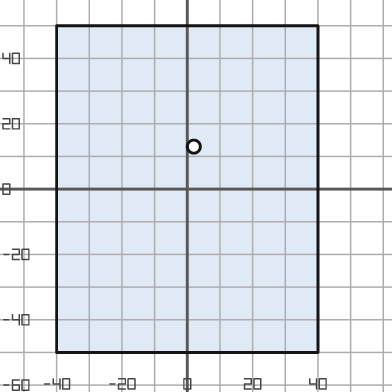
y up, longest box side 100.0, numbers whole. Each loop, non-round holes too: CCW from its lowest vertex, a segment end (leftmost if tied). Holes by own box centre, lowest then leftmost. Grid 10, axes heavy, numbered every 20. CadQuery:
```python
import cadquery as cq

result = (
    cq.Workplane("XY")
    .moveTo(-40.0, -50.0)
    .lineTo(40.0, -50.0)
    .lineTo(40.0, 50.0)
    .lineTo(-40.0, 50.0)
    .close()
    .moveTo(2.0, 13.0)
    .circle(2.0)
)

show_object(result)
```